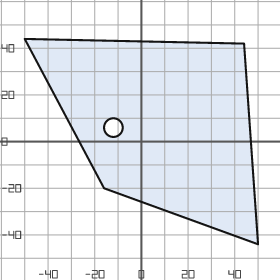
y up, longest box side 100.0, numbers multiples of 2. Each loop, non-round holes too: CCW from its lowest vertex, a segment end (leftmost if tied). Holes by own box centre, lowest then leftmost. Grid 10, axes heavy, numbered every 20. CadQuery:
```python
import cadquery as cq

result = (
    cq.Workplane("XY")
    .moveTo(50.0, -44.0)
    .lineTo(44.0, 42.0)
    .lineTo(-50.0, 44.0)
    .lineTo(-16.0, -20.0)
    .close()
    .moveTo(-12.0, 6.0)
    .circle(4.0)
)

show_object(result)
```